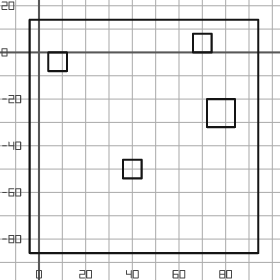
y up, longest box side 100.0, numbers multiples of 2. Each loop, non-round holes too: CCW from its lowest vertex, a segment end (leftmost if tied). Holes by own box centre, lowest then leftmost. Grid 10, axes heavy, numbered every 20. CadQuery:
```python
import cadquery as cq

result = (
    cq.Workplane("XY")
    .moveTo(-4.0, -86.0)
    .lineTo(94.0, -86.0)
    .lineTo(94.0, 14.0)
    .lineTo(-4.0, 14.0)
    .close()
    .moveTo(36.0, -54.0)
    .lineTo(44.0, -54.0)
    .lineTo(44.0, -46.0)
    .lineTo(36.0, -46.0)
    .close()
    .moveTo(72.0, -32.0)
    .lineTo(84.0, -32.0)
    .lineTo(84.0, -20.0)
    .lineTo(72.0, -20.0)
    .close()
    .moveTo(4.0, -8.0)
    .lineTo(12.0, -8.0)
    .lineTo(12.0, 0.0)
    .lineTo(4.0, 0.0)
    .close()
    .moveTo(66.0, 0.0)
    .lineTo(74.0, 0.0)
    .lineTo(74.0, 8.0)
    .lineTo(66.0, 8.0)
    .close()
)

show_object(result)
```